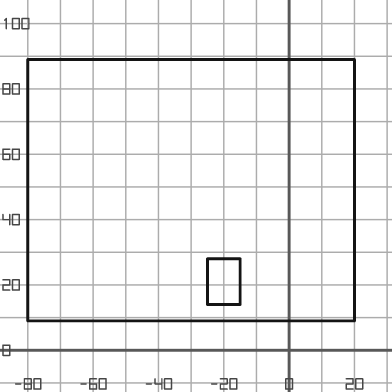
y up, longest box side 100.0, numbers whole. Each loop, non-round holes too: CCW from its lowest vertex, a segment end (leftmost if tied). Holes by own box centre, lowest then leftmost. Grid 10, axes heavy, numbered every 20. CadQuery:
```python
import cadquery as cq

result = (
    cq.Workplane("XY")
    .moveTo(-80.0, 9.0)
    .lineTo(20.0, 9.0)
    .lineTo(20.0, 89.0)
    .lineTo(-80.0, 89.0)
    .close()
    .moveTo(-25.0, 14.0)
    .lineTo(-15.0, 14.0)
    .lineTo(-15.0, 28.0)
    .lineTo(-25.0, 28.0)
    .close()
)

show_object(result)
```